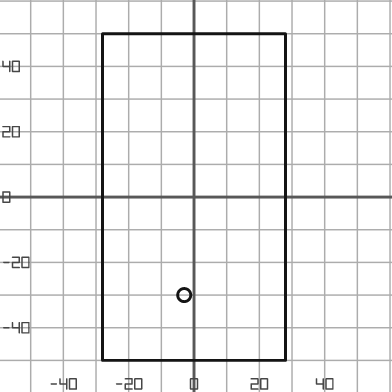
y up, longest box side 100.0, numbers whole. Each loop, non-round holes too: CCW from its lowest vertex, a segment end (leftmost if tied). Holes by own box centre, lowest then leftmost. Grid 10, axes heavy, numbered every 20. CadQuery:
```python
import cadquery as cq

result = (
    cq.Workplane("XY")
    .moveTo(-28.0, -50.0)
    .lineTo(28.0, -50.0)
    .lineTo(28.0, 50.0)
    .lineTo(-28.0, 50.0)
    .close()
    .moveTo(-3.0, -30.0)
    .circle(2.0)
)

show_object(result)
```